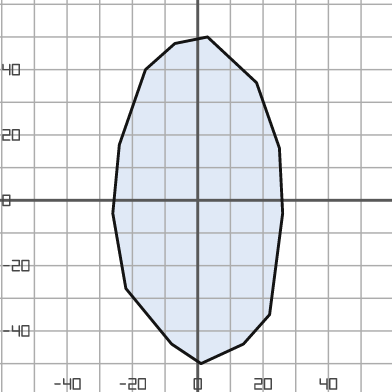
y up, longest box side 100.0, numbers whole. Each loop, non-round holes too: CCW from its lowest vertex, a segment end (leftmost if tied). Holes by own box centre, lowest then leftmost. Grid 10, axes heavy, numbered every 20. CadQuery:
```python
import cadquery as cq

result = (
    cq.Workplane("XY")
    .moveTo(1.0, -50.0)
    .lineTo(14.0, -44.0)
    .lineTo(22.0, -35.0)
    .lineTo(26.0, -4.0)
    .lineTo(25.0, 16.0)
    .lineTo(18.0, 36.0)
    .lineTo(3.0, 50.0)
    .lineTo(-7.0, 48.0)
    .lineTo(-16.0, 40.0)
    .lineTo(-24.0, 17.0)
    .lineTo(-26.0, -4.0)
    .lineTo(-22.0, -27.0)
    .lineTo(-8.0, -44.0)
    .close()
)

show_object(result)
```